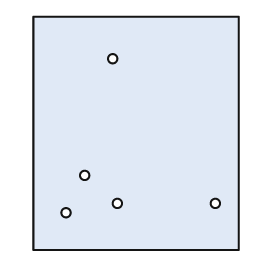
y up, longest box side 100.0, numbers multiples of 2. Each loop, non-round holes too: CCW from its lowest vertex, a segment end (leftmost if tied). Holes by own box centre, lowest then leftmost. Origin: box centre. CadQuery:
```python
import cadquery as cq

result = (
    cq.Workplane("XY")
    .moveTo(-44.0, -50.0)
    .lineTo(44.0, -50.0)
    .lineTo(44.0, 50.0)
    .lineTo(-44.0, 50.0)
    .close()
    .moveTo(-30.0, -34.0)
    .circle(2.0)
    .moveTo(-8.0, -30.0)
    .circle(2.0)
    .moveTo(34.0, -30.0)
    .circle(2.0)
    .moveTo(-22.0, -18.0)
    .circle(2.0)
    .moveTo(-10.0, 32.0)
    .circle(2.0)
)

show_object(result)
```